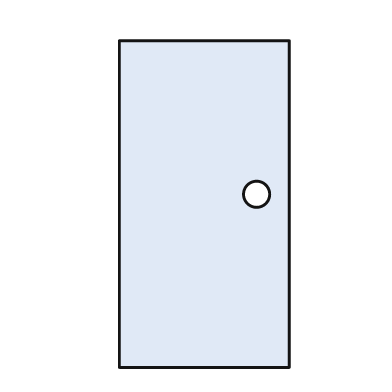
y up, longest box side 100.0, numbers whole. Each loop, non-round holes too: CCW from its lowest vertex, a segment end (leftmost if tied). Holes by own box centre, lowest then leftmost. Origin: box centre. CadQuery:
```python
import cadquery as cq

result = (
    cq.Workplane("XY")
    .moveTo(-26.0, -50.0)
    .lineTo(26.0, -50.0)
    .lineTo(26.0, 50.0)
    .lineTo(-26.0, 50.0)
    .close()
    .moveTo(16.0, 3.0)
    .circle(4.0)
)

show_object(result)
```